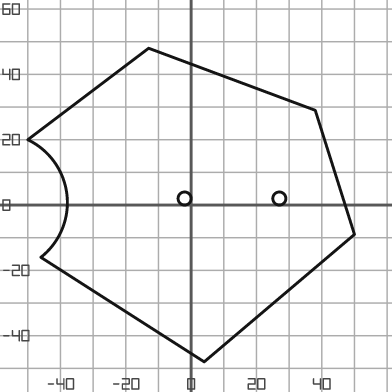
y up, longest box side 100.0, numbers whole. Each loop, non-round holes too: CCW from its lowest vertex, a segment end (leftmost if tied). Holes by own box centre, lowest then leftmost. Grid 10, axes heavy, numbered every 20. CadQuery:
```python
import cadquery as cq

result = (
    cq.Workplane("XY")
    .moveTo(4.0, -48.0)
    .lineTo(50.0, -9.0)
    .lineTo(38.0, 29.0)
    .lineTo(-13.0, 48.0)
    .lineTo(-50.0, 20.0)
    .threePointArc((-38.0, 3.0), (-46.0, -16.0))
    .close()
    .moveTo(-2.0, 2.0)
    .circle(2.0)
    .moveTo(27.0, 2.0)
    .circle(2.0)
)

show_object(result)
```